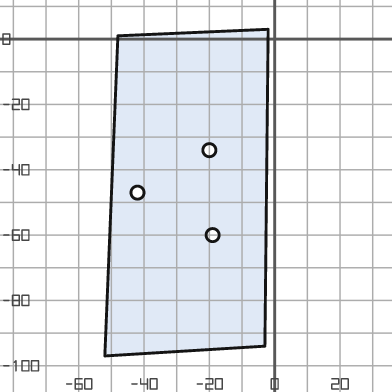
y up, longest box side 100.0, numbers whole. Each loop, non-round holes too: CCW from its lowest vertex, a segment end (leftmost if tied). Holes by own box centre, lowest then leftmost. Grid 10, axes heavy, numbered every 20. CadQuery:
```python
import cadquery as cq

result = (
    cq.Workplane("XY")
    .moveTo(-52.0, -97.0)
    .lineTo(-3.0, -94.0)
    .lineTo(-2.0, 3.0)
    .lineTo(-48.0, 1.0)
    .close()
    .moveTo(-19.0, -60.0)
    .circle(2.0)
    .moveTo(-42.0, -47.0)
    .circle(2.0)
    .moveTo(-20.0, -34.0)
    .circle(2.0)
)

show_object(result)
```